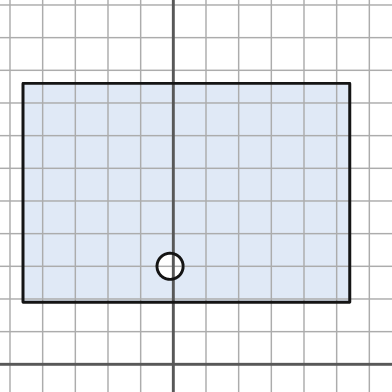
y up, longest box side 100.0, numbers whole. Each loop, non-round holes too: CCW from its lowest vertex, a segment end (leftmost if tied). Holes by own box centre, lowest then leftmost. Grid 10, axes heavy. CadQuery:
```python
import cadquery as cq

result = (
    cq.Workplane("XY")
    .moveTo(-46.0, 19.0)
    .lineTo(54.0, 19.0)
    .lineTo(54.0, 86.0)
    .lineTo(-46.0, 86.0)
    .close()
    .moveTo(-1.0, 30.0)
    .circle(4.0)
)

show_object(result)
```